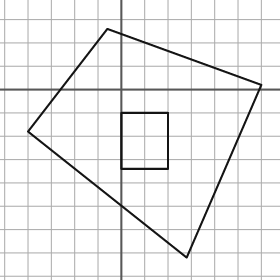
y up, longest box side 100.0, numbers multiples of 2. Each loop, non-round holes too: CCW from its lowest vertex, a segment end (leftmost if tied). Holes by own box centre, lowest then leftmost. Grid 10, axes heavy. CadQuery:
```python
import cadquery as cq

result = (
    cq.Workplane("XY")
    .moveTo(28.0, -72.0)
    .lineTo(60.0, 2.0)
    .lineTo(-6.0, 26.0)
    .lineTo(-40.0, -18.0)
    .close()
    .moveTo(0.0, -34.0)
    .lineTo(20.0, -34.0)
    .lineTo(20.0, -10.0)
    .lineTo(0.0, -10.0)
    .close()
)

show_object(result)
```